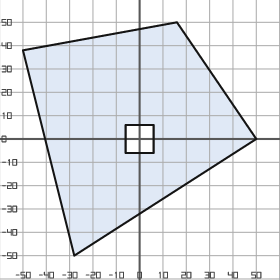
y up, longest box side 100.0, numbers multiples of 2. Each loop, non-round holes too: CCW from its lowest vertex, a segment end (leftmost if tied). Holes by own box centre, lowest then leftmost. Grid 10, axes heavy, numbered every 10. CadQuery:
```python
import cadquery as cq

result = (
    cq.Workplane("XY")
    .moveTo(-28.0, -50.0)
    .lineTo(50.0, 0.0)
    .lineTo(16.0, 50.0)
    .lineTo(-50.0, 38.0)
    .close()
    .moveTo(-6.0, -6.0)
    .lineTo(6.0, -6.0)
    .lineTo(6.0, 6.0)
    .lineTo(-6.0, 6.0)
    .close()
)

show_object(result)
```